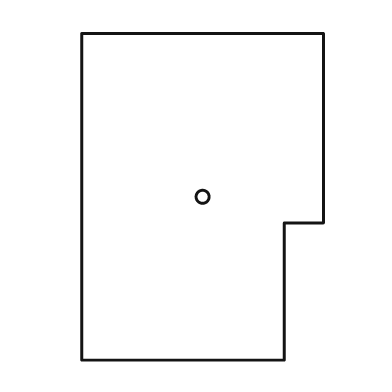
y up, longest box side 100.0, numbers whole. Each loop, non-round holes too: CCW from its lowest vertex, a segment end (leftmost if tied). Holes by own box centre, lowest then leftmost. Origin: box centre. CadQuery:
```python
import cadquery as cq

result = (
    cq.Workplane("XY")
    .moveTo(-37.0, -50.0)
    .lineTo(25.0, -50.0)
    .lineTo(25.0, -8.0)
    .lineTo(37.0, -8.0)
    .lineTo(37.0, 50.0)
    .lineTo(-37.0, 50.0)
    .close()
    .moveTo(0.0, 0.0)
    .circle(2.0)
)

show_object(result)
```